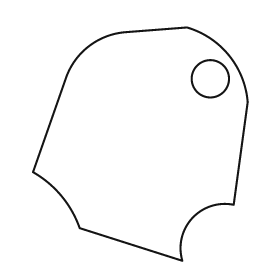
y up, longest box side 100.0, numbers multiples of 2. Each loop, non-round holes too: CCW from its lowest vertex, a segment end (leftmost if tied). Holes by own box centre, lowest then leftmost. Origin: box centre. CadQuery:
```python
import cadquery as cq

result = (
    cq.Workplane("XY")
    .moveTo(18.0, -50.0)
    .threePointArc((22.0, -32.0), (40.0, -26.0))
    .lineTo(46.0, 18.0)
    .threePointArc((38.0, 38.0), (20.0, 50.0))
    .lineTo(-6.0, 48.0)
    .threePointArc((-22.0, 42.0), (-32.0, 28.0))
    .lineTo(-46.0, -12.0)
    .threePointArc((-34.0, -22.0), (-26.0, -36.0))
    .close()
    .moveTo(30.0, 28.0)
    .circle(8.0)
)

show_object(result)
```